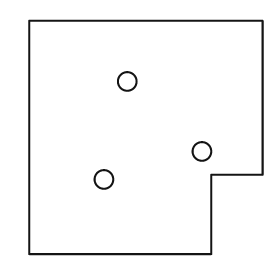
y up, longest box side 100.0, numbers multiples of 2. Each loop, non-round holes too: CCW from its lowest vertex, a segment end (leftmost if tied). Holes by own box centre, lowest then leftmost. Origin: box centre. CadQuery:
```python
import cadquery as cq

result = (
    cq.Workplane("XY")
    .moveTo(-50.0, -50.0)
    .lineTo(28.0, -50.0)
    .lineTo(28.0, -16.0)
    .lineTo(50.0, -16.0)
    .lineTo(50.0, 50.0)
    .lineTo(-50.0, 50.0)
    .close()
    .moveTo(-18.0, -18.0)
    .circle(4.0)
    .moveTo(24.0, -6.0)
    .circle(4.0)
    .moveTo(-8.0, 24.0)
    .circle(4.0)
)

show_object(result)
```